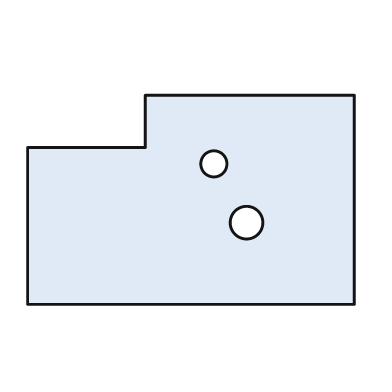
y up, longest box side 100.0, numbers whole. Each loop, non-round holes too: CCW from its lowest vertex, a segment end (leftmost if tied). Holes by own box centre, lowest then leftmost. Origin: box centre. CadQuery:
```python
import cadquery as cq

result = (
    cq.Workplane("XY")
    .moveTo(-50.0, -32.0)
    .lineTo(50.0, -32.0)
    .lineTo(50.0, 32.0)
    .lineTo(-14.0, 32.0)
    .lineTo(-14.0, 16.0)
    .lineTo(-50.0, 16.0)
    .close()
    .moveTo(17.0, -7.0)
    .circle(5.0)
    .moveTo(7.0, 11.0)
    .circle(4.0)
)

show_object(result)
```